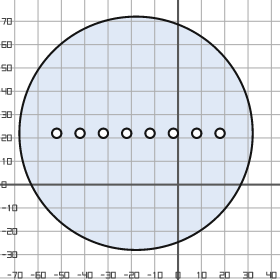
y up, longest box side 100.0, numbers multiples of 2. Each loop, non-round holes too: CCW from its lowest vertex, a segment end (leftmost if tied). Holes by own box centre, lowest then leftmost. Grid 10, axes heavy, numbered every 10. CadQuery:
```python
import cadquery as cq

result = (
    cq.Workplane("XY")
    .moveTo(-18.0, 22.0)
    .circle(50.0)
    .moveTo(-52.0, 22.0)
    .circle(2.0)
    .moveTo(-42.0, 22.0)
    .circle(2.0)
    .moveTo(-32.0, 22.0)
    .circle(2.0)
    .moveTo(-22.0, 22.0)
    .circle(2.0)
    .moveTo(-12.0, 22.0)
    .circle(2.0)
    .moveTo(-2.0, 22.0)
    .circle(2.0)
    .moveTo(8.0, 22.0)
    .circle(2.0)
    .moveTo(18.0, 22.0)
    .circle(2.0)
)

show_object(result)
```